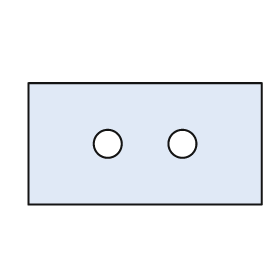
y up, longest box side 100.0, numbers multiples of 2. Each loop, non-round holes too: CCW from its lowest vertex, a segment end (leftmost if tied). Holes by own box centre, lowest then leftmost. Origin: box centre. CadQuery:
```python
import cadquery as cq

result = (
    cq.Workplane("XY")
    .moveTo(-50.0, -26.0)
    .lineTo(50.0, -26.0)
    .lineTo(50.0, 26.0)
    .lineTo(-50.0, 26.0)
    .close()
    .moveTo(-16.0, 0.0)
    .circle(6.0)
    .moveTo(16.0, 0.0)
    .circle(6.0)
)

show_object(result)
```